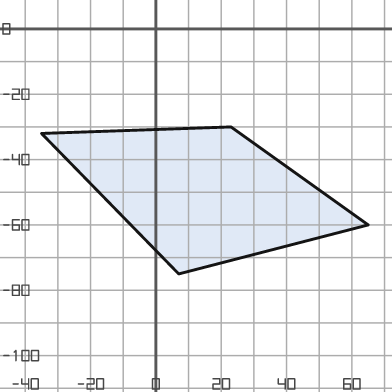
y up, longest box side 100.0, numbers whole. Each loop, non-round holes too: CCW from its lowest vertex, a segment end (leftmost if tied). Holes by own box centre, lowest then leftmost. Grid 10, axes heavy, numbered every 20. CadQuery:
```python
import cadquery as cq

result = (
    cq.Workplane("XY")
    .moveTo(7.0, -75.0)
    .lineTo(65.0, -60.0)
    .lineTo(23.0, -30.0)
    .lineTo(-35.0, -32.0)
    .close()
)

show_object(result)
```